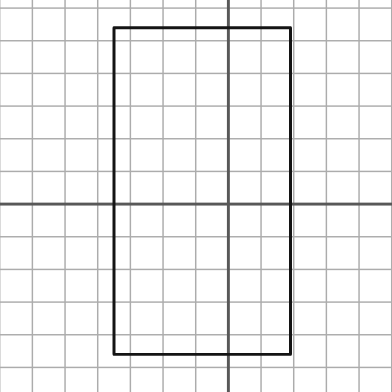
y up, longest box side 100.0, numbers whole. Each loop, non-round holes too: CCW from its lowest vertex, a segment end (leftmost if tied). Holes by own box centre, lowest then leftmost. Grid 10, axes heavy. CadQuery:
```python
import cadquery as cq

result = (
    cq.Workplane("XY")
    .moveTo(-35.0, -46.0)
    .lineTo(19.0, -46.0)
    .lineTo(19.0, 54.0)
    .lineTo(-35.0, 54.0)
    .close()
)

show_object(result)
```